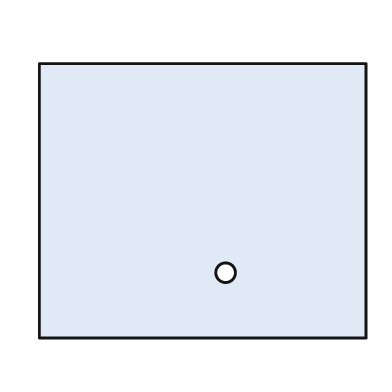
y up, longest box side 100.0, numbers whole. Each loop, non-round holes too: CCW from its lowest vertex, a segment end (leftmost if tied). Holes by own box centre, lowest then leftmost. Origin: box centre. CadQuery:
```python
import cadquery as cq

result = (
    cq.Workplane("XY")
    .moveTo(-50.0, -42.0)
    .lineTo(50.0, -42.0)
    .lineTo(50.0, 42.0)
    .lineTo(-50.0, 42.0)
    .close()
    .moveTo(7.0, -22.0)
    .circle(3.0)
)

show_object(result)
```